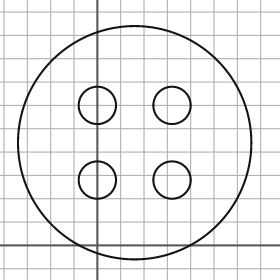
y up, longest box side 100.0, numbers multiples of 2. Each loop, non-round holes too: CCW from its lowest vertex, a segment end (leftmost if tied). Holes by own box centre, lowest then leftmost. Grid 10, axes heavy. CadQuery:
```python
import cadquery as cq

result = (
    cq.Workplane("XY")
    .moveTo(16.0, 44.0)
    .circle(50.0)
    .moveTo(0.0, 28.0)
    .circle(8.0)
    .moveTo(32.0, 28.0)
    .circle(8.0)
    .moveTo(0.0, 60.0)
    .circle(8.0)
    .moveTo(32.0, 60.0)
    .circle(8.0)
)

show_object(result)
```